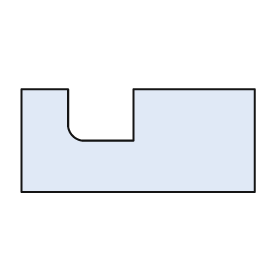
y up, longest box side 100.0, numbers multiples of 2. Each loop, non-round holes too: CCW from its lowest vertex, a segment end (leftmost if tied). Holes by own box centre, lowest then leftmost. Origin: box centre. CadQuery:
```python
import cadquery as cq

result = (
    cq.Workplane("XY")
    .moveTo(-50.0, -22.0)
    .lineTo(50.0, -22.0)
    .lineTo(50.0, 22.0)
    .lineTo(-2.0, 22.0)
    .lineTo(-2.0, 0.0)
    .lineTo(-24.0, 0.0)
    .threePointArc((-28.0, 2.0), (-30.0, 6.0))
    .lineTo(-30.0, 22.0)
    .lineTo(-50.0, 22.0)
    .close()
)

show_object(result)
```